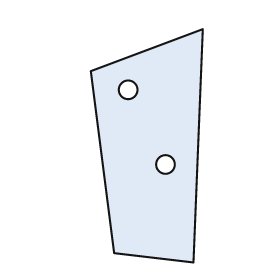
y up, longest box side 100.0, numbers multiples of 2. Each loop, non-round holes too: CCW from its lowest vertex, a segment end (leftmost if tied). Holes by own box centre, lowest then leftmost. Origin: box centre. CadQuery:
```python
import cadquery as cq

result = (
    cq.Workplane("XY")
    .moveTo(20.0, -50.0)
    .lineTo(24.0, 50.0)
    .lineTo(-24.0, 32.0)
    .lineTo(-14.0, -46.0)
    .close()
    .moveTo(8.0, -8.0)
    .circle(4.0)
    .moveTo(-8.0, 24.0)
    .circle(4.0)
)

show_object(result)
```